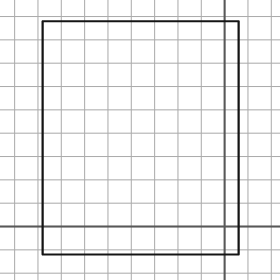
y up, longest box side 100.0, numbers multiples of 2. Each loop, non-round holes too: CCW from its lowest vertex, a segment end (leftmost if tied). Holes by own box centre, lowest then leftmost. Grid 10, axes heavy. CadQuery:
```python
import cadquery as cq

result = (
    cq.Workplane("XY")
    .moveTo(-78.0, -12.0)
    .lineTo(6.0, -12.0)
    .lineTo(6.0, 88.0)
    .lineTo(-78.0, 88.0)
    .close()
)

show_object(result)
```